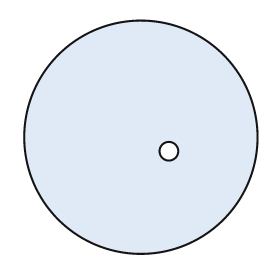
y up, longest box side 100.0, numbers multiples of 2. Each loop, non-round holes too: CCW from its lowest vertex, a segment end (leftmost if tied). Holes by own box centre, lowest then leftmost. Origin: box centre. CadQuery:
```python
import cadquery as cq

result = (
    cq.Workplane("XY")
    .moveTo(0.0, 0.0)
    .circle(50.0)
    .moveTo(12.0, -6.0)
    .circle(4.0)
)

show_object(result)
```